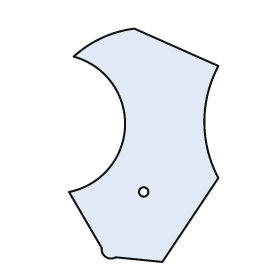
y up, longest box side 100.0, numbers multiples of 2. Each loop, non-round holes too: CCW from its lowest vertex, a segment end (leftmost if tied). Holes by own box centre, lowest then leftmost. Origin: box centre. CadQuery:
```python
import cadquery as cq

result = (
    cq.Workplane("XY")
    .moveTo(8.0, -50.0)
    .lineTo(32.0, -14.0)
    .threePointArc((26.0, 10.0), (32.0, 34.0))
    .lineTo(-4.0, 50.0)
    .threePointArc((-18.0, 46.0), (-30.0, 38.0))
    .threePointArc((-8.0, 8.0), (-32.0, -20.0))
    .lineTo(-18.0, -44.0)
    .threePointArc((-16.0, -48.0), (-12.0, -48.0))
    .close()
    .moveTo(0.0, -20.0)
    .circle(2.0)
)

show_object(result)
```